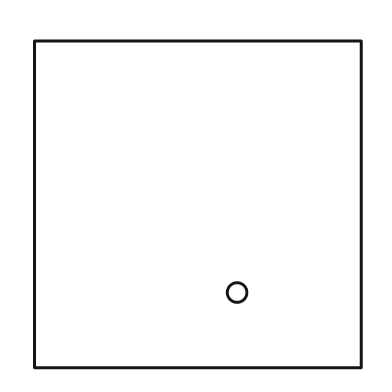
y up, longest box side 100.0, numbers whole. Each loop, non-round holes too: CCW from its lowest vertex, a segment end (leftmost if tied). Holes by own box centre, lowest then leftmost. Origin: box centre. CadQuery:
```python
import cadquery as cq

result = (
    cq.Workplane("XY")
    .moveTo(-50.0, -50.0)
    .lineTo(50.0, -50.0)
    .lineTo(50.0, 50.0)
    .lineTo(-50.0, 50.0)
    .close()
    .moveTo(12.0, -27.0)
    .circle(3.0)
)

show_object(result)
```